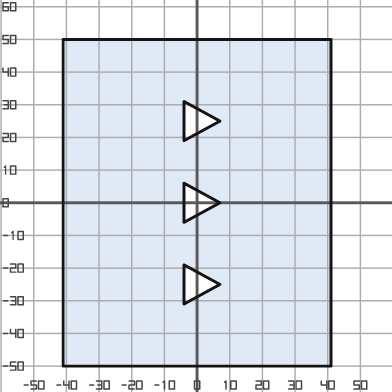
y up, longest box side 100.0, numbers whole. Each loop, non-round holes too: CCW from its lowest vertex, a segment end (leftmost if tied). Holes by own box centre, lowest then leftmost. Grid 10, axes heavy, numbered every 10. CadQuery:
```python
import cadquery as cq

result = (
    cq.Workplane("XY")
    .moveTo(-41.0, -50.0)
    .lineTo(41.0, -50.0)
    .lineTo(41.0, 50.0)
    .lineTo(-41.0, 50.0)
    .close()
    .moveTo(-4.0, -31.0)
    .lineTo(7.0, -25.0)
    .lineTo(-4.0, -19.0)
    .close()
    .moveTo(-4.0, -6.0)
    .lineTo(7.0, 0.0)
    .lineTo(-4.0, 6.0)
    .close()
    .moveTo(-4.0, 19.0)
    .lineTo(7.0, 25.0)
    .lineTo(-4.0, 31.0)
    .close()
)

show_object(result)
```